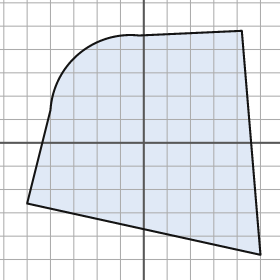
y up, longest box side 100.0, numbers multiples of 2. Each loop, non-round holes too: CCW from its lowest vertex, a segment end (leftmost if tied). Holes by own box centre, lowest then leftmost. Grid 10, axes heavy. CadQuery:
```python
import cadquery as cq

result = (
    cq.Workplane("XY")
    .moveTo(50.0, -48.0)
    .lineTo(42.0, 48.0)
    .lineTo(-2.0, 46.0)
    .threePointArc((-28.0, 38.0), (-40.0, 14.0))
    .lineTo(-50.0, -26.0)
    .close()
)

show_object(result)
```